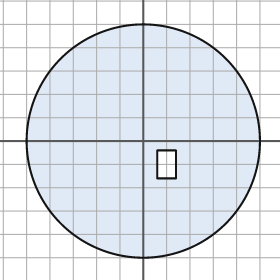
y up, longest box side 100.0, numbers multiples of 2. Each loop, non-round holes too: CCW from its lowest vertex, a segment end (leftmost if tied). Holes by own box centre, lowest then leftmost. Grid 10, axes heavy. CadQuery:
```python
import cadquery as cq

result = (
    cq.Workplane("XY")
    .moveTo(0.0, 0.0)
    .circle(50.0)
    .moveTo(6.0, -16.0)
    .lineTo(14.0, -16.0)
    .lineTo(14.0, -4.0)
    .lineTo(6.0, -4.0)
    .close()
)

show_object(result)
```